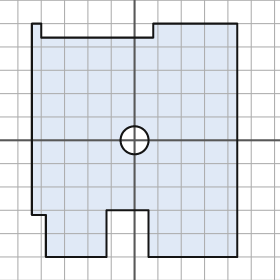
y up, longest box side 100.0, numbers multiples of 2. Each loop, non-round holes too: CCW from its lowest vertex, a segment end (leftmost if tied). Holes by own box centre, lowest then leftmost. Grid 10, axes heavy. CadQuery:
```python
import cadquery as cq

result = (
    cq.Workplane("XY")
    .moveTo(-38.0, -50.0)
    .lineTo(-12.0, -50.0)
    .lineTo(-12.0, -30.0)
    .lineTo(6.0, -30.0)
    .lineTo(6.0, -50.0)
    .lineTo(44.0, -50.0)
    .lineTo(44.0, 50.0)
    .lineTo(8.0, 50.0)
    .lineTo(8.0, 44.0)
    .lineTo(-40.0, 44.0)
    .lineTo(-40.0, 50.0)
    .lineTo(-44.0, 50.0)
    .lineTo(-44.0, -32.0)
    .lineTo(-38.0, -32.0)
    .close()
    .moveTo(0.0, 0.0)
    .circle(6.0)
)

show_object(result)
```